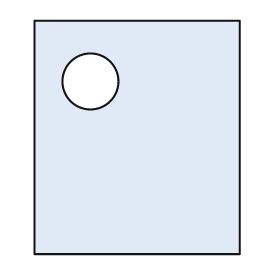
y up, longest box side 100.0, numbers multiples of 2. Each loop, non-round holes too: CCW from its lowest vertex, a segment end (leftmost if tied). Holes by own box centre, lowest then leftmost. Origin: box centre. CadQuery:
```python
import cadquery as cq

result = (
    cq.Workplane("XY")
    .moveTo(-44.0, -50.0)
    .lineTo(44.0, -50.0)
    .lineTo(44.0, 50.0)
    .lineTo(-44.0, 50.0)
    .close()
    .moveTo(-20.0, 24.0)
    .circle(12.0)
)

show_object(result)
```